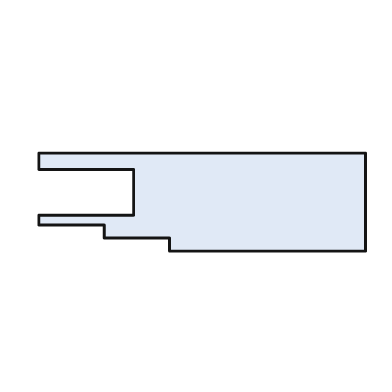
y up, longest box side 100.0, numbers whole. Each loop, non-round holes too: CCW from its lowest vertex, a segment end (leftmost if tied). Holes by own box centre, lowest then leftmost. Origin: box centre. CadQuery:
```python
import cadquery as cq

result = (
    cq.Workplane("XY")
    .moveTo(-10.0, -15.0)
    .lineTo(50.0, -15.0)
    .lineTo(50.0, 15.0)
    .lineTo(-50.0, 15.0)
    .lineTo(-50.0, 10.0)
    .lineTo(-21.0, 10.0)
    .lineTo(-21.0, -4.0)
    .lineTo(-50.0, -4.0)
    .lineTo(-50.0, -7.0)
    .lineTo(-30.0, -7.0)
    .lineTo(-30.0, -11.0)
    .lineTo(-10.0, -11.0)
    .close()
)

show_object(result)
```